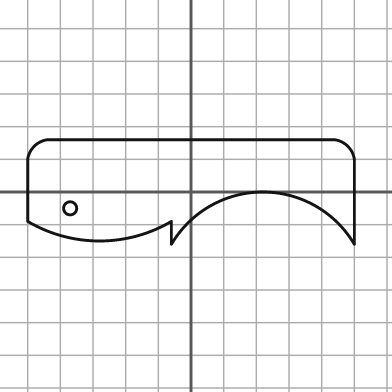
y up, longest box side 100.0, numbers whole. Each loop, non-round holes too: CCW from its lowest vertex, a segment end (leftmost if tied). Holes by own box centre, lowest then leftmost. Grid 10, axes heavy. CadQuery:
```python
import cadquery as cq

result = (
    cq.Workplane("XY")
    .moveTo(-6.0, -16.0)
    .threePointArc((22.0, 0.0), (50.0, -16.0))
    .lineTo(50.0, 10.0)
    .threePointArc((48.0, 14.0), (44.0, 16.0))
    .lineTo(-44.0, 16.0)
    .threePointArc((-48.0, 14.0), (-50.0, 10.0))
    .lineTo(-50.0, -9.0)
    .threePointArc((-28.0, -15.0), (-6.0, -9.0))
    .close()
    .moveTo(-37.0, -5.0)
    .circle(2.0)
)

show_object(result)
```